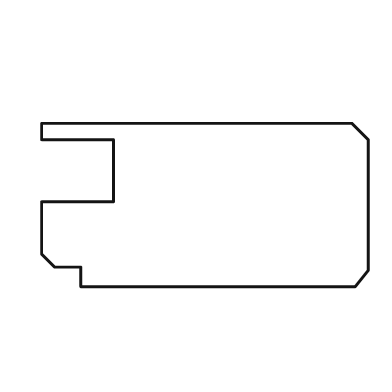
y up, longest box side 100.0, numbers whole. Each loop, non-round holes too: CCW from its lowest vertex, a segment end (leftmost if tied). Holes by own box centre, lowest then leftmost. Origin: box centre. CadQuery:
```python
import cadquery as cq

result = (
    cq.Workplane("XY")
    .moveTo(-38.0, -25.0)
    .lineTo(46.0, -25.0)
    .lineTo(50.0, -20.0)
    .lineTo(50.0, 20.0)
    .lineTo(45.0, 25.0)
    .lineTo(-50.0, 25.0)
    .lineTo(-50.0, 20.0)
    .lineTo(-28.0, 20.0)
    .lineTo(-28.0, 1.0)
    .lineTo(-50.0, 1.0)
    .lineTo(-50.0, -15.0)
    .lineTo(-46.0, -19.0)
    .lineTo(-38.0, -19.0)
    .close()
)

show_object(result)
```